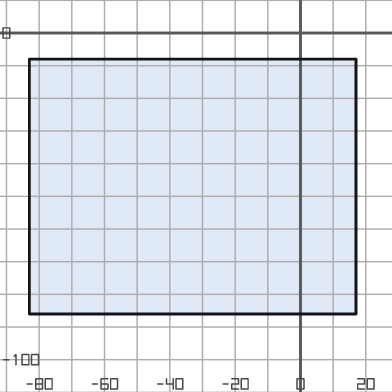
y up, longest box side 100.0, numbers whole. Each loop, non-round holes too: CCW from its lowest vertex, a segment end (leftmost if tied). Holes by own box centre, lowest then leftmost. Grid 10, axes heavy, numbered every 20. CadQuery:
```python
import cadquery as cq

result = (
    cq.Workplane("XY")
    .moveTo(-83.0, -86.0)
    .lineTo(17.0, -86.0)
    .lineTo(17.0, -8.0)
    .lineTo(-83.0, -8.0)
    .close()
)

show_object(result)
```